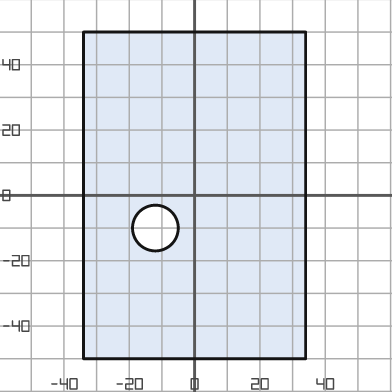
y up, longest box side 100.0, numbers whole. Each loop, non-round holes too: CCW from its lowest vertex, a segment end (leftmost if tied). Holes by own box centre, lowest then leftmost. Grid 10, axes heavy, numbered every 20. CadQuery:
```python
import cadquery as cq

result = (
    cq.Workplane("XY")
    .moveTo(-34.0, -50.0)
    .lineTo(34.0, -50.0)
    .lineTo(34.0, 50.0)
    .lineTo(-34.0, 50.0)
    .close()
    .moveTo(-12.0, -10.0)
    .circle(7.0)
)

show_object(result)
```